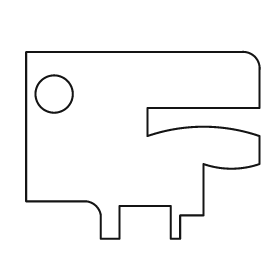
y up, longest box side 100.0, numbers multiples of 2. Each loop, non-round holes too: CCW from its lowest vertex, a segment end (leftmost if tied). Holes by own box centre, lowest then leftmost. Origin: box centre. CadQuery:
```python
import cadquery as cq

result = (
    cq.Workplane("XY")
    .moveTo(-18.0, -40.0)
    .lineTo(-10.0, -40.0)
    .lineTo(-10.0, -26.0)
    .lineTo(12.0, -26.0)
    .lineTo(12.0, -40.0)
    .lineTo(16.0, -40.0)
    .lineTo(16.0, -30.0)
    .lineTo(26.0, -30.0)
    .lineTo(26.0, -8.0)
    .threePointArc((38.0, -10.0), (50.0, -8.0))
    .lineTo(50.0, 4.0)
    .threePointArc((26.0, 8.0), (2.0, 4.0))
    .lineTo(2.0, 16.0)
    .lineTo(50.0, 16.0)
    .lineTo(50.0, 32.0)
    .threePointArc((48.0, 38.0), (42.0, 40.0))
    .lineTo(-50.0, 40.0)
    .lineTo(-50.0, -24.0)
    .lineTo(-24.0, -24.0)
    .threePointArc((-20.0, -26.0), (-18.0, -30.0))
    .close()
    .moveTo(-38.0, 22.0)
    .circle(8.0)
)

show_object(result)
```